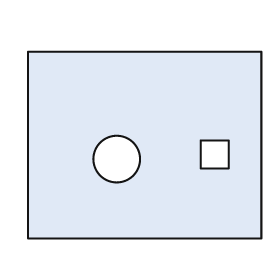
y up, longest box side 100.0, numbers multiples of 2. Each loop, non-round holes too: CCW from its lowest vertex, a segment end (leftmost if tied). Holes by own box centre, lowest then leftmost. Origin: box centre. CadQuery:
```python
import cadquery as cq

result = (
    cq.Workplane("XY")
    .moveTo(-50.0, -40.0)
    .lineTo(50.0, -40.0)
    .lineTo(50.0, 40.0)
    .lineTo(-50.0, 40.0)
    .close()
    .moveTo(-12.0, -6.0)
    .circle(10.0)
    .moveTo(24.0, -10.0)
    .lineTo(36.0, -10.0)
    .lineTo(36.0, 2.0)
    .lineTo(24.0, 2.0)
    .close()
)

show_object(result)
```